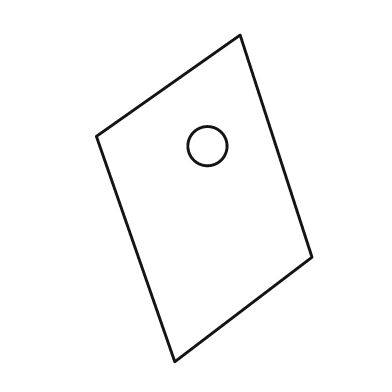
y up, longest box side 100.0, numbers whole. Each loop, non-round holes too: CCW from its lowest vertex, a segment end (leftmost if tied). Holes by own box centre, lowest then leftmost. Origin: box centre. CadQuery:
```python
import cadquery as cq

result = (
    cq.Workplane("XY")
    .moveTo(-9.0, -50.0)
    .lineTo(33.0, -18.0)
    .lineTo(11.0, 50.0)
    .lineTo(-33.0, 19.0)
    .close()
    .moveTo(1.0, 16.0)
    .circle(6.0)
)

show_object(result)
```